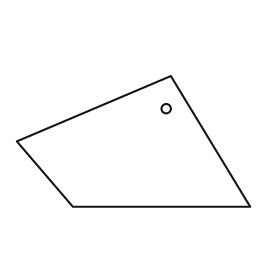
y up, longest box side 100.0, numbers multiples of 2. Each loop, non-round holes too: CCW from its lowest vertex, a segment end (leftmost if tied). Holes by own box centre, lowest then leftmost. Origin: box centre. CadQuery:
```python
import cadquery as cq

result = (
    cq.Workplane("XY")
    .moveTo(-26.0, -28.0)
    .lineTo(50.0, -28.0)
    .lineTo(16.0, 28.0)
    .lineTo(-50.0, 0.0)
    .close()
    .moveTo(14.0, 14.0)
    .circle(2.0)
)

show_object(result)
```